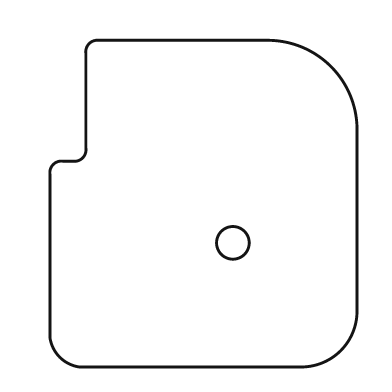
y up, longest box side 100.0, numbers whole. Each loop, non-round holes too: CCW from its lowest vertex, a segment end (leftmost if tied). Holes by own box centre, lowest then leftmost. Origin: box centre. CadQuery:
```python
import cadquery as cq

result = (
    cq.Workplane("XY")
    .moveTo(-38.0, -50.0)
    .lineTo(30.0, -50.0)
    .threePointArc((42.0, -45.0), (47.0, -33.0))
    .lineTo(47.0, 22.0)
    .threePointArc((39.0, 42.0), (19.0, 50.0))
    .lineTo(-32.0, 50.0)
    .threePointArc((-35.0, 49.0), (-36.0, 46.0))
    .lineTo(-36.0, 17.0)
    .threePointArc((-37.0, 14.0), (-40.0, 13.0))
    .lineTo(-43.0, 13.0)
    .threePointArc((-46.0, 12.0), (-47.0, 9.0))
    .lineTo(-47.0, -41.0)
    .threePointArc((-44.0, -47.0), (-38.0, -50.0))
    .close()
    .moveTo(9.0, -12.0)
    .circle(5.0)
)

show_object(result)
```